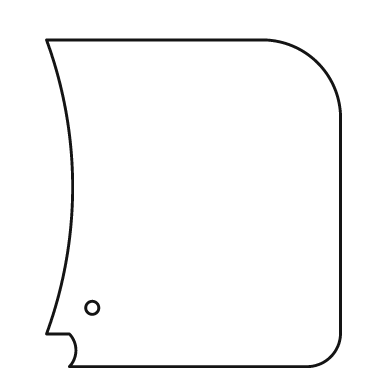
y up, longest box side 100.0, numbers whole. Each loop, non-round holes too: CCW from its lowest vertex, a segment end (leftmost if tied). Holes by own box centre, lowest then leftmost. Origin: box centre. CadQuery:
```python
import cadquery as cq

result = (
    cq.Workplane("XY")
    .moveTo(-38.0, -50.0)
    .lineTo(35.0, -50.0)
    .threePointArc((42.0, -47.0), (45.0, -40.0))
    .lineTo(45.0, 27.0)
    .threePointArc((38.0, 43.0), (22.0, 50.0))
    .lineTo(-45.0, 50.0)
    .threePointArc((-37.0, 5.0), (-45.0, -40.0))
    .lineTo(-38.0, -40.0)
    .threePointArc((-36.0, -45.0), (-38.0, -50.0))
    .close()
    .moveTo(-31.0, -32.0)
    .circle(2.0)
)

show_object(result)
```